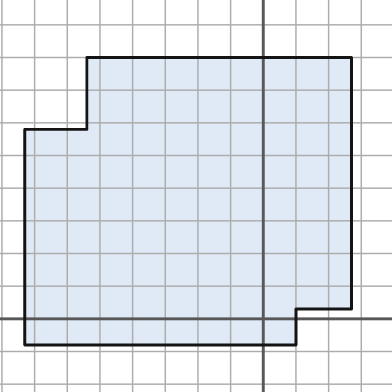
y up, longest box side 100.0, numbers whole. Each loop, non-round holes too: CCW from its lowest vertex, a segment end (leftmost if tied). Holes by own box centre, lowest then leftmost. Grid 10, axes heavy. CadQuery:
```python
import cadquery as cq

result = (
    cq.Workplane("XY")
    .moveTo(-73.0, -8.0)
    .lineTo(10.0, -8.0)
    .lineTo(10.0, 3.0)
    .lineTo(27.0, 3.0)
    .lineTo(27.0, 80.0)
    .lineTo(-54.0, 80.0)
    .lineTo(-54.0, 58.0)
    .lineTo(-73.0, 58.0)
    .close()
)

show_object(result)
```